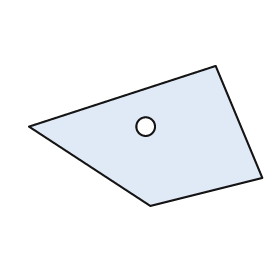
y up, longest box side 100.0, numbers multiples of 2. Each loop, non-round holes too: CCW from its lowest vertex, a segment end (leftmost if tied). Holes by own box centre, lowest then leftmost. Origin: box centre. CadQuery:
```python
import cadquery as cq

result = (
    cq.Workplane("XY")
    .moveTo(2.0, -30.0)
    .lineTo(50.0, -18.0)
    .lineTo(30.0, 30.0)
    .lineTo(-50.0, 4.0)
    .close()
    .moveTo(0.0, 4.0)
    .circle(4.0)
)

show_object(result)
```